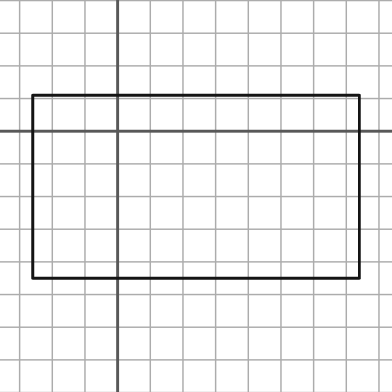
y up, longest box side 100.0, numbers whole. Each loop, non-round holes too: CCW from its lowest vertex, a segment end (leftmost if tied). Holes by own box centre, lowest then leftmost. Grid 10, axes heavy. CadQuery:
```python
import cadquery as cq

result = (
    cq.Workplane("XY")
    .moveTo(-26.0, -45.0)
    .lineTo(74.0, -45.0)
    .lineTo(74.0, 11.0)
    .lineTo(-26.0, 11.0)
    .close()
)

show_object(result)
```